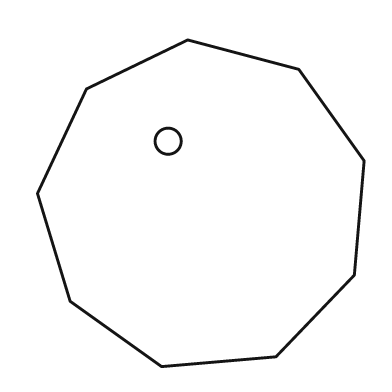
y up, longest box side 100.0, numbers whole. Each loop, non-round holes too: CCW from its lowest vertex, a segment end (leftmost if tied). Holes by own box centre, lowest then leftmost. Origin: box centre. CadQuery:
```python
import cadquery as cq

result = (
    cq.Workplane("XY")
    .moveTo(-12.0, -50.0)
    .lineTo(23.0, -47.0)
    .lineTo(47.0, -22.0)
    .lineTo(50.0, 13.0)
    .lineTo(30.0, 41.0)
    .lineTo(-4.0, 50.0)
    .lineTo(-35.0, 35.0)
    .lineTo(-50.0, 3.0)
    .lineTo(-40.0, -30.0)
    .close()
    .moveTo(-10.0, 19.0)
    .circle(4.0)
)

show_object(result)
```